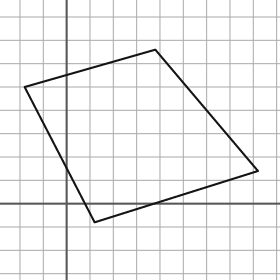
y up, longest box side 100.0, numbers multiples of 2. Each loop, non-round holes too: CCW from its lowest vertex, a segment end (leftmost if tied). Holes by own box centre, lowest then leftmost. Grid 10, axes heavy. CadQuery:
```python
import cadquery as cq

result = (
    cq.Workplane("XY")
    .moveTo(12.0, -8.0)
    .lineTo(82.0, 14.0)
    .lineTo(38.0, 66.0)
    .lineTo(-18.0, 50.0)
    .close()
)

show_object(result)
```